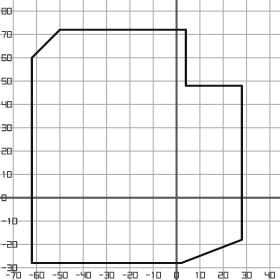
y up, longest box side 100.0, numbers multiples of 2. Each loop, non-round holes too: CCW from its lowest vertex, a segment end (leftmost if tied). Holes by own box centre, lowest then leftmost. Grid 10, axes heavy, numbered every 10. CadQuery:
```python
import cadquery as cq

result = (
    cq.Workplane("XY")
    .moveTo(-62.0, -28.0)
    .lineTo(2.0, -28.0)
    .lineTo(28.0, -18.0)
    .lineTo(28.0, 48.0)
    .lineTo(4.0, 48.0)
    .lineTo(4.0, 72.0)
    .lineTo(-50.0, 72.0)
    .lineTo(-62.0, 60.0)
    .close()
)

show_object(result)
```